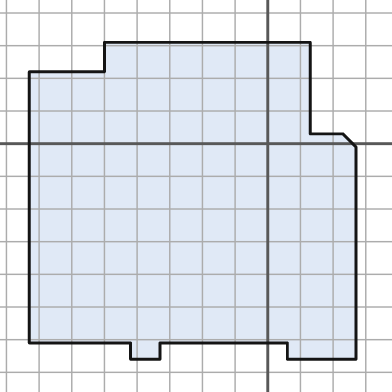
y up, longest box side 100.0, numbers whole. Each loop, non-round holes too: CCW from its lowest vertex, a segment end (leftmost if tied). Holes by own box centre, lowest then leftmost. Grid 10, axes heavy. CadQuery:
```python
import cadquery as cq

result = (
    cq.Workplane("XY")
    .moveTo(-42.0, -66.0)
    .lineTo(-33.0, -66.0)
    .lineTo(-33.0, -61.0)
    .lineTo(6.0, -61.0)
    .lineTo(6.0, -66.0)
    .lineTo(27.0, -66.0)
    .lineTo(27.0, -1.0)
    .lineTo(23.0, 3.0)
    .lineTo(13.0, 3.0)
    .lineTo(13.0, 31.0)
    .lineTo(-50.0, 31.0)
    .lineTo(-50.0, 22.0)
    .lineTo(-73.0, 22.0)
    .lineTo(-73.0, -61.0)
    .lineTo(-42.0, -61.0)
    .close()
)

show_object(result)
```